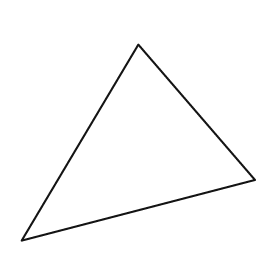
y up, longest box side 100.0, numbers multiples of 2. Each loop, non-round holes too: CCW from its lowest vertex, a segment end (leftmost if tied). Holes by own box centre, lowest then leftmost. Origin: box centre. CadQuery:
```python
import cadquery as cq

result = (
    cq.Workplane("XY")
    .moveTo(-50.0, -42.0)
    .lineTo(50.0, -16.0)
    .lineTo(0.0, 42.0)
    .close()
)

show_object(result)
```